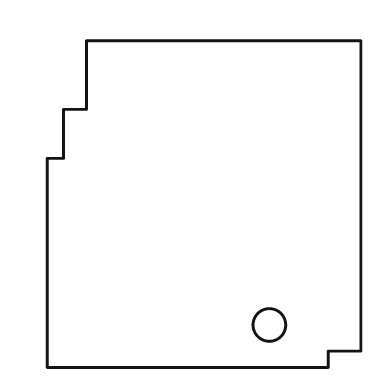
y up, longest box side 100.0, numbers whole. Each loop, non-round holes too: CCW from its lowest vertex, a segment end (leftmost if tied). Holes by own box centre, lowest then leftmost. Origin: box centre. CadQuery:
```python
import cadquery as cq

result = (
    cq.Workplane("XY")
    .moveTo(-48.0, -50.0)
    .lineTo(38.0, -50.0)
    .lineTo(38.0, -45.0)
    .lineTo(48.0, -45.0)
    .lineTo(48.0, 50.0)
    .lineTo(-36.0, 50.0)
    .lineTo(-36.0, 29.0)
    .lineTo(-43.0, 29.0)
    .lineTo(-43.0, 14.0)
    .lineTo(-48.0, 14.0)
    .close()
    .moveTo(20.0, -37.0)
    .circle(5.0)
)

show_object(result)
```